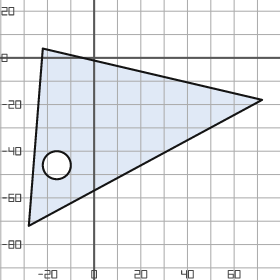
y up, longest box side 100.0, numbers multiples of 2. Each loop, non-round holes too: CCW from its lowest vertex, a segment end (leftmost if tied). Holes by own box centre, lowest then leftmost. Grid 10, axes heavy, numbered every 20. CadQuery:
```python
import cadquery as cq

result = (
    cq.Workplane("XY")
    .moveTo(-28.0, -72.0)
    .lineTo(72.0, -18.0)
    .lineTo(-22.0, 4.0)
    .close()
    .moveTo(-16.0, -46.0)
    .circle(6.0)
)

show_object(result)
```